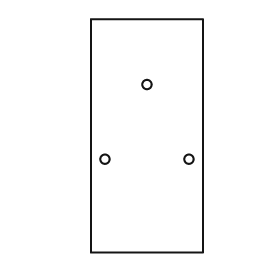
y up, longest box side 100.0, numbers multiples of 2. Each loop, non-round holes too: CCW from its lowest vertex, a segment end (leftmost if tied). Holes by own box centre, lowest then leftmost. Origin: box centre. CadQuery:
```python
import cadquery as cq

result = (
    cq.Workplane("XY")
    .moveTo(-24.0, -50.0)
    .lineTo(24.0, -50.0)
    .lineTo(24.0, 50.0)
    .lineTo(-24.0, 50.0)
    .close()
    .moveTo(-18.0, -10.0)
    .circle(2.0)
    .moveTo(18.0, -10.0)
    .circle(2.0)
    .moveTo(0.0, 22.0)
    .circle(2.0)
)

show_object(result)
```